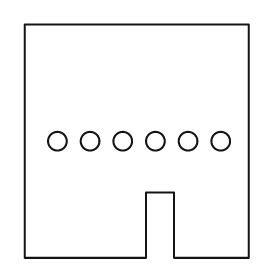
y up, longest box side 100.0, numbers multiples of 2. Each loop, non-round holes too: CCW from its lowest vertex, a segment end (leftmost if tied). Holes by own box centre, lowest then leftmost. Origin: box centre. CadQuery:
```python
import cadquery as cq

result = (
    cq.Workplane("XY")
    .moveTo(-48.0, -50.0)
    .lineTo(4.0, -50.0)
    .lineTo(4.0, -22.0)
    .lineTo(16.0, -22.0)
    .lineTo(16.0, -50.0)
    .lineTo(48.0, -50.0)
    .lineTo(48.0, 50.0)
    .lineTo(-48.0, 50.0)
    .close()
    .moveTo(-34.0, 0.0)
    .circle(4.0)
    .moveTo(-20.0, 0.0)
    .circle(4.0)
    .moveTo(-6.0, 0.0)
    .circle(4.0)
    .moveTo(8.0, 0.0)
    .circle(4.0)
    .moveTo(22.0, 0.0)
    .circle(4.0)
    .moveTo(36.0, 0.0)
    .circle(4.0)
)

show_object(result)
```